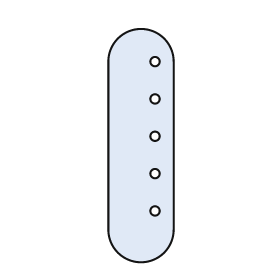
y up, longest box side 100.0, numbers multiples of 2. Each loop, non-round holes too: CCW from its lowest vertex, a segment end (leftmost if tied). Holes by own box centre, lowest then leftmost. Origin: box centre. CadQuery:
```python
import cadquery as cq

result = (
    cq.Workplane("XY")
    .moveTo(-14.0, -36.0)
    .threePointArc((0.0, -50.0), (14.0, -36.0))
    .lineTo(14.0, 36.0)
    .threePointArc((0.0, 50.0), (-14.0, 36.0))
    .close()
    .moveTo(6.0, -28.0)
    .circle(2.0)
    .moveTo(6.0, -12.0)
    .circle(2.0)
    .moveTo(6.0, 4.0)
    .circle(2.0)
    .moveTo(6.0, 20.0)
    .circle(2.0)
    .moveTo(6.0, 36.0)
    .circle(2.0)
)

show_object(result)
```